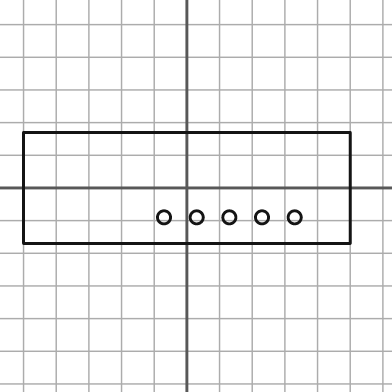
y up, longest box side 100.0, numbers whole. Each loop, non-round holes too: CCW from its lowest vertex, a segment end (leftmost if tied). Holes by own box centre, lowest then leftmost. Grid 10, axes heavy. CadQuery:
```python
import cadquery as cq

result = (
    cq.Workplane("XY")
    .moveTo(-50.0, -17.0)
    .lineTo(50.0, -17.0)
    .lineTo(50.0, 17.0)
    .lineTo(-50.0, 17.0)
    .close()
    .moveTo(-7.0, -9.0)
    .circle(2.0)
    .moveTo(3.0, -9.0)
    .circle(2.0)
    .moveTo(13.0, -9.0)
    .circle(2.0)
    .moveTo(23.0, -9.0)
    .circle(2.0)
    .moveTo(33.0, -9.0)
    .circle(2.0)
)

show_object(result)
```